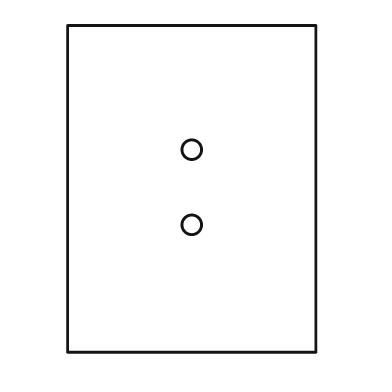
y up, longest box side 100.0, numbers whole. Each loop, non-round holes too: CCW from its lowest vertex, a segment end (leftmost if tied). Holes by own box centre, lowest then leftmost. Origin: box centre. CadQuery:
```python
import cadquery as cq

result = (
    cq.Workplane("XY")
    .moveTo(-38.0, -50.0)
    .lineTo(38.0, -50.0)
    .lineTo(38.0, 50.0)
    .lineTo(-38.0, 50.0)
    .close()
    .moveTo(0.0, -11.0)
    .circle(3.0)
    .moveTo(0.0, 12.0)
    .circle(3.0)
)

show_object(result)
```